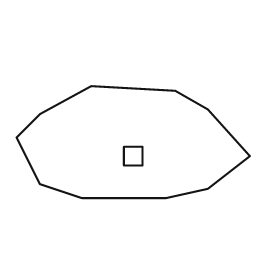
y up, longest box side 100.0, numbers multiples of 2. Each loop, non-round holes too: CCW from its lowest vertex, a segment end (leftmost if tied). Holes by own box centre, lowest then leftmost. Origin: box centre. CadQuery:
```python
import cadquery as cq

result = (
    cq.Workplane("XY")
    .moveTo(-22.0, -24.0)
    .lineTo(14.0, -24.0)
    .lineTo(32.0, -20.0)
    .lineTo(50.0, -6.0)
    .lineTo(32.0, 14.0)
    .lineTo(18.0, 22.0)
    .lineTo(-18.0, 24.0)
    .lineTo(-40.0, 12.0)
    .lineTo(-50.0, 2.0)
    .lineTo(-40.0, -18.0)
    .close()
    .moveTo(-4.0, -10.0)
    .lineTo(4.0, -10.0)
    .lineTo(4.0, -2.0)
    .lineTo(-4.0, -2.0)
    .close()
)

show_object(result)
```